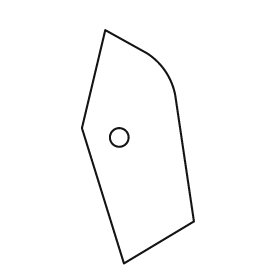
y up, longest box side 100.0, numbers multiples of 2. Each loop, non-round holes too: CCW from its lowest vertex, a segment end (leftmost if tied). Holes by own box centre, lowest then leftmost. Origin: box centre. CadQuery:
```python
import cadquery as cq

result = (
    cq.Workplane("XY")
    .moveTo(-6.0, -50.0)
    .lineTo(24.0, -32.0)
    .lineTo(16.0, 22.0)
    .threePointArc((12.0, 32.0), (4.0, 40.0))
    .lineTo(-14.0, 50.0)
    .lineTo(-24.0, 8.0)
    .close()
    .moveTo(-8.0, 4.0)
    .circle(4.0)
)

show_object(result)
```